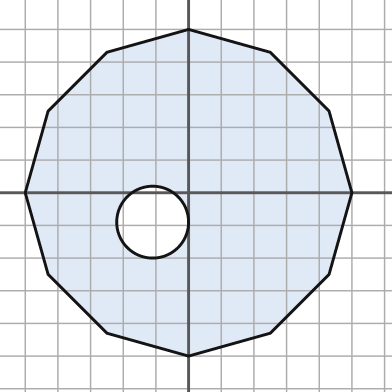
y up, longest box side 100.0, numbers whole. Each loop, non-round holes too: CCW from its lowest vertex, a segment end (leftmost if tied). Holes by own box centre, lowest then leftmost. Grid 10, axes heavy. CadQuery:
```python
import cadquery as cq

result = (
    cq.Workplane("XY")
    .moveTo(0.0, -50.0)
    .lineTo(25.0, -43.0)
    .lineTo(43.0, -25.0)
    .lineTo(50.0, 0.0)
    .lineTo(43.0, 25.0)
    .lineTo(25.0, 43.0)
    .lineTo(0.0, 50.0)
    .lineTo(-25.0, 43.0)
    .lineTo(-43.0, 25.0)
    .lineTo(-50.0, 0.0)
    .lineTo(-43.0, -25.0)
    .lineTo(-25.0, -43.0)
    .close()
    .moveTo(-11.0, -9.0)
    .circle(11.0)
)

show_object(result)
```